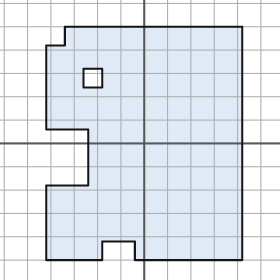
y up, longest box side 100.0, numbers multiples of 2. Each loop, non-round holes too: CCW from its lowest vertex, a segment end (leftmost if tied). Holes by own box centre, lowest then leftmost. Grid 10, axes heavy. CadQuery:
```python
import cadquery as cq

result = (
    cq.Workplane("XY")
    .moveTo(-42.0, -50.0)
    .lineTo(-18.0, -50.0)
    .lineTo(-18.0, -42.0)
    .lineTo(-4.0, -42.0)
    .lineTo(-4.0, -50.0)
    .lineTo(42.0, -50.0)
    .lineTo(42.0, 50.0)
    .lineTo(-34.0, 50.0)
    .lineTo(-34.0, 42.0)
    .lineTo(-42.0, 42.0)
    .lineTo(-42.0, 6.0)
    .lineTo(-24.0, 6.0)
    .lineTo(-24.0, -18.0)
    .lineTo(-42.0, -18.0)
    .close()
    .moveTo(-26.0, 24.0)
    .lineTo(-18.0, 24.0)
    .lineTo(-18.0, 32.0)
    .lineTo(-26.0, 32.0)
    .close()
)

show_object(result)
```